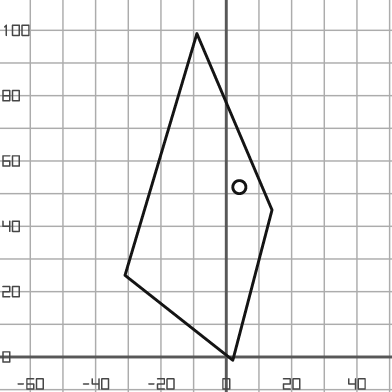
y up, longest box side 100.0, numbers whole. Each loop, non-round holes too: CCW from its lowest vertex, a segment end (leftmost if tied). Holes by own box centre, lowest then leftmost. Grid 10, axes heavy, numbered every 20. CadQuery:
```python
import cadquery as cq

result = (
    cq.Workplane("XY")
    .moveTo(2.0, -1.0)
    .lineTo(14.0, 45.0)
    .lineTo(-9.0, 99.0)
    .lineTo(-31.0, 25.0)
    .close()
    .moveTo(4.0, 52.0)
    .circle(2.0)
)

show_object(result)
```